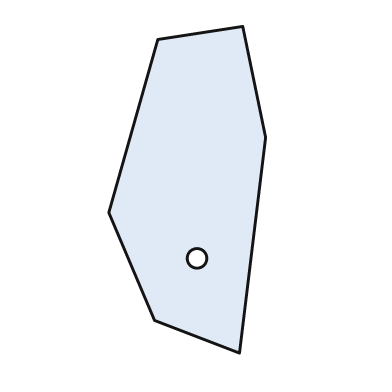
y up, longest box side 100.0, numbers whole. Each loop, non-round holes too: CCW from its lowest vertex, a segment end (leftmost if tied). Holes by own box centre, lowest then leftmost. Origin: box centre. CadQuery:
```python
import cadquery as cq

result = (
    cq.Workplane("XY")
    .moveTo(16.0, -50.0)
    .lineTo(24.0, 16.0)
    .lineTo(17.0, 50.0)
    .lineTo(-9.0, 46.0)
    .lineTo(-24.0, -7.0)
    .lineTo(-10.0, -40.0)
    .close()
    .moveTo(3.0, -21.0)
    .circle(3.0)
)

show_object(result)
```